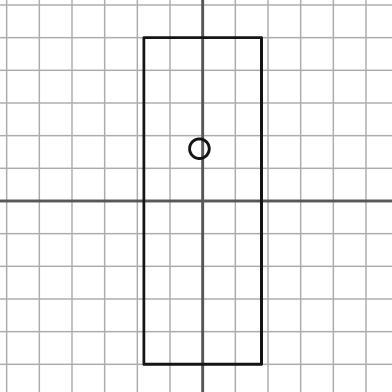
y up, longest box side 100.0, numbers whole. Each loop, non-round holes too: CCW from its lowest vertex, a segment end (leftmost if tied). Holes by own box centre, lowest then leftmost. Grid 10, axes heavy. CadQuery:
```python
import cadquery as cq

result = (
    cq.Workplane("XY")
    .moveTo(-18.0, -50.0)
    .lineTo(18.0, -50.0)
    .lineTo(18.0, 50.0)
    .lineTo(-18.0, 50.0)
    .close()
    .moveTo(-1.0, 16.0)
    .circle(3.0)
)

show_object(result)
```